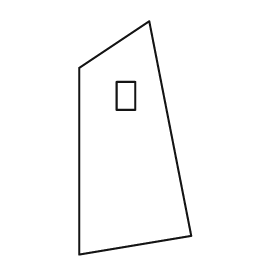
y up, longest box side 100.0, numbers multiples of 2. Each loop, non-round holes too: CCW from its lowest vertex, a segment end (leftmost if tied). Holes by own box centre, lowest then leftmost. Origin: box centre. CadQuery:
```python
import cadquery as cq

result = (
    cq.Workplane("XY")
    .moveTo(-24.0, -50.0)
    .lineTo(24.0, -42.0)
    .lineTo(6.0, 50.0)
    .lineTo(-24.0, 30.0)
    .close()
    .moveTo(-8.0, 12.0)
    .lineTo(0.0, 12.0)
    .lineTo(0.0, 24.0)
    .lineTo(-8.0, 24.0)
    .close()
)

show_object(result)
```